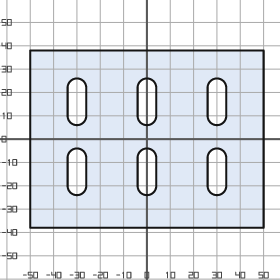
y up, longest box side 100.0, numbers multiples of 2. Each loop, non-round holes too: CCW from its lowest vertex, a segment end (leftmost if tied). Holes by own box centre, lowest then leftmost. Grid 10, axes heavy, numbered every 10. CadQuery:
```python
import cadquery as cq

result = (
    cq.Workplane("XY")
    .moveTo(-50.0, -38.0)
    .lineTo(50.0, -38.0)
    .lineTo(50.0, 38.0)
    .lineTo(-50.0, 38.0)
    .close()
    .moveTo(-34.0, -20.0)
    .threePointArc((-30.0, -24.0), (-26.0, -20.0))
    .lineTo(-26.0, -8.0)
    .threePointArc((-30.0, -4.0), (-34.0, -8.0))
    .close()
    .moveTo(-4.0, -20.0)
    .threePointArc((0.0, -24.0), (4.0, -20.0))
    .lineTo(4.0, -8.0)
    .threePointArc((0.0, -4.0), (-4.0, -8.0))
    .close()
    .moveTo(26.0, -20.0)
    .threePointArc((30.0, -24.0), (34.0, -20.0))
    .lineTo(34.0, -8.0)
    .threePointArc((30.0, -4.0), (26.0, -8.0))
    .close()
    .moveTo(-34.0, 10.0)
    .threePointArc((-30.0, 6.0), (-26.0, 10.0))
    .lineTo(-26.0, 22.0)
    .threePointArc((-30.0, 26.0), (-34.0, 22.0))
    .close()
    .moveTo(-4.0, 10.0)
    .threePointArc((0.0, 6.0), (4.0, 10.0))
    .lineTo(4.0, 22.0)
    .threePointArc((0.0, 26.0), (-4.0, 22.0))
    .close()
    .moveTo(26.0, 10.0)
    .threePointArc((30.0, 6.0), (34.0, 10.0))
    .lineTo(34.0, 22.0)
    .threePointArc((30.0, 26.0), (26.0, 22.0))
    .close()
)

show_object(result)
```